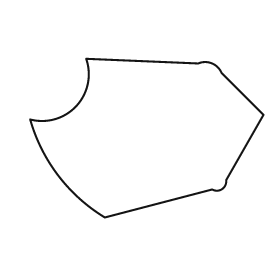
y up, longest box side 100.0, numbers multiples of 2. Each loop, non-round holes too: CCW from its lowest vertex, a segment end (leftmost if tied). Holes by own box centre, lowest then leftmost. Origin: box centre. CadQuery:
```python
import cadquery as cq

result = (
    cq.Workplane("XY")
    .moveTo(-18.0, -34.0)
    .lineTo(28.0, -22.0)
    .threePointArc((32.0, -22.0), (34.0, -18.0))
    .lineTo(50.0, 10.0)
    .lineTo(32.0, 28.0)
    .threePointArc((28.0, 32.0), (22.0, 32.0))
    .lineTo(-26.0, 34.0)
    .threePointArc((-30.0, 14.0), (-50.0, 8.0))
    .threePointArc((-38.0, -16.0), (-18.0, -34.0))
    .close()
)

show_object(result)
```